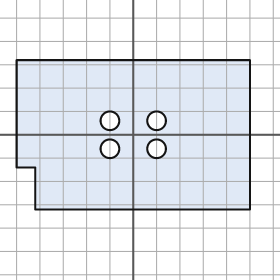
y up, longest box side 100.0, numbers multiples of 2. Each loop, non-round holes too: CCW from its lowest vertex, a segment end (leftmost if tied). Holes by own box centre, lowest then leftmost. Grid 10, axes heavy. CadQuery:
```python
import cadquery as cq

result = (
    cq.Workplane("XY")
    .moveTo(-42.0, -32.0)
    .lineTo(50.0, -32.0)
    .lineTo(50.0, 32.0)
    .lineTo(-50.0, 32.0)
    .lineTo(-50.0, -14.0)
    .lineTo(-42.0, -14.0)
    .close()
    .moveTo(-10.0, -6.0)
    .circle(4.0)
    .moveTo(10.0, -6.0)
    .circle(4.0)
    .moveTo(-10.0, 6.0)
    .circle(4.0)
    .moveTo(10.0, 6.0)
    .circle(4.0)
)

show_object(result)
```